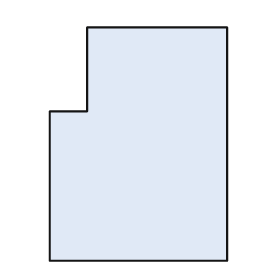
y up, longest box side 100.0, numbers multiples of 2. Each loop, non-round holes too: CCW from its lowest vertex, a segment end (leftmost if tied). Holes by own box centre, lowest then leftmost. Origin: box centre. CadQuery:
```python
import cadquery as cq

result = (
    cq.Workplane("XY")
    .moveTo(-38.0, -50.0)
    .lineTo(38.0, -50.0)
    .lineTo(38.0, 50.0)
    .lineTo(-22.0, 50.0)
    .lineTo(-22.0, 14.0)
    .lineTo(-38.0, 14.0)
    .close()
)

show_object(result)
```